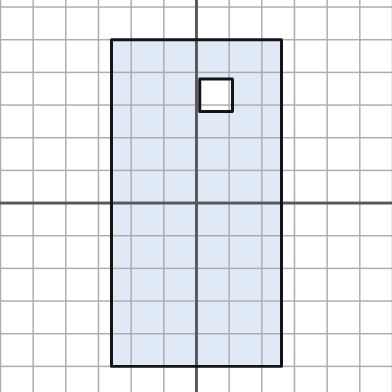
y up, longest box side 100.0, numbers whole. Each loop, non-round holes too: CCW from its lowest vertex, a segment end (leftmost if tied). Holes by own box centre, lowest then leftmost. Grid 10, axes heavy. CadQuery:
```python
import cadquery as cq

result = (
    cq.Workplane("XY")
    .moveTo(-26.0, -50.0)
    .lineTo(26.0, -50.0)
    .lineTo(26.0, 50.0)
    .lineTo(-26.0, 50.0)
    .close()
    .moveTo(1.0, 28.0)
    .lineTo(11.0, 28.0)
    .lineTo(11.0, 38.0)
    .lineTo(1.0, 38.0)
    .close()
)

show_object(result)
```